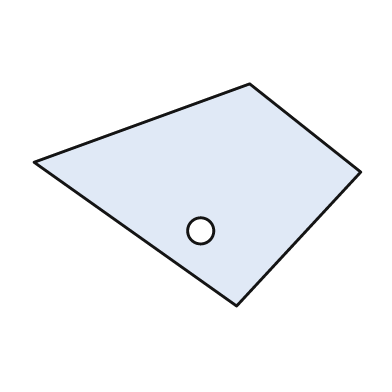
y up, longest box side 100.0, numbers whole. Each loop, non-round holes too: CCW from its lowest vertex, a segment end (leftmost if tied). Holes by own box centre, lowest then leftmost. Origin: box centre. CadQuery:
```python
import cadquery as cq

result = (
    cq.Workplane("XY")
    .moveTo(12.0, -34.0)
    .lineTo(50.0, 7.0)
    .lineTo(16.0, 34.0)
    .lineTo(-50.0, 10.0)
    .close()
    .moveTo(1.0, -11.0)
    .circle(4.0)
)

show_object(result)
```